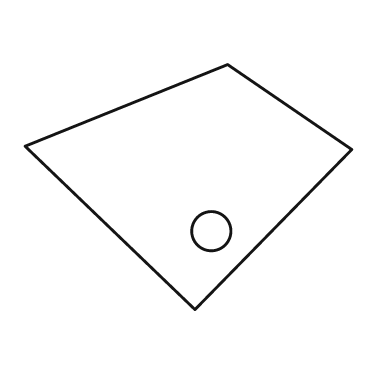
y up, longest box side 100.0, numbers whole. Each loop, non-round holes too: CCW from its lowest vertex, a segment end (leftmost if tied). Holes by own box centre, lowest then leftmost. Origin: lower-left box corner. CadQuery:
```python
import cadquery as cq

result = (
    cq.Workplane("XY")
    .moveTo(52.0, 0.0)
    .lineTo(100.0, 49.0)
    .lineTo(62.0, 75.0)
    .lineTo(0.0, 50.0)
    .close()
    .moveTo(57.0, 24.0)
    .circle(6.0)
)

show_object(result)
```